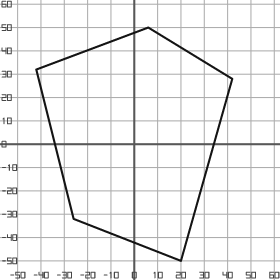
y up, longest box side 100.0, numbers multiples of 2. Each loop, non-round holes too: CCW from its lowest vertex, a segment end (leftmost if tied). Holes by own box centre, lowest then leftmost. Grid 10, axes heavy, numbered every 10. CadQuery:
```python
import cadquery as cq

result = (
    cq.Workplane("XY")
    .moveTo(20.0, -50.0)
    .lineTo(42.0, 28.0)
    .lineTo(6.0, 50.0)
    .lineTo(-42.0, 32.0)
    .lineTo(-26.0, -32.0)
    .close()
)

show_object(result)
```